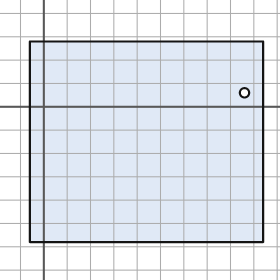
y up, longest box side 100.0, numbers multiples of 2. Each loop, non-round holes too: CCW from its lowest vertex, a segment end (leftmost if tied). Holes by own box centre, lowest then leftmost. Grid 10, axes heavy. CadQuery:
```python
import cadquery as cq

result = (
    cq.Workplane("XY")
    .moveTo(-6.0, -58.0)
    .lineTo(94.0, -58.0)
    .lineTo(94.0, 28.0)
    .lineTo(-6.0, 28.0)
    .close()
    .moveTo(86.0, 6.0)
    .circle(2.0)
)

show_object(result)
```